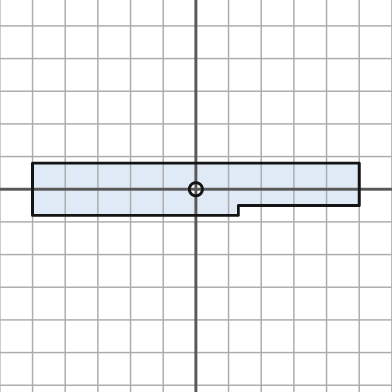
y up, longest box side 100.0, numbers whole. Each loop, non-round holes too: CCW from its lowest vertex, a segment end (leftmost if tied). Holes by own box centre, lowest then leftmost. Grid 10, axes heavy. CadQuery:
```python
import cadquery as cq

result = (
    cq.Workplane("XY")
    .moveTo(-50.0, -8.0)
    .lineTo(13.0, -8.0)
    .lineTo(13.0, -5.0)
    .lineTo(50.0, -5.0)
    .lineTo(50.0, 8.0)
    .lineTo(-50.0, 8.0)
    .close()
    .moveTo(0.0, 0.0)
    .circle(2.0)
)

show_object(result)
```